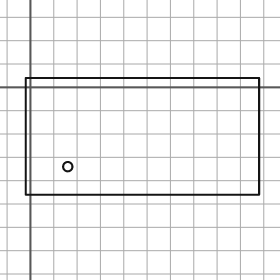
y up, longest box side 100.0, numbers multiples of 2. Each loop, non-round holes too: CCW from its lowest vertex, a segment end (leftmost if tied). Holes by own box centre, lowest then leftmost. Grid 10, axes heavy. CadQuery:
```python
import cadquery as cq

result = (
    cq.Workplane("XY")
    .moveTo(-2.0, -46.0)
    .lineTo(98.0, -46.0)
    .lineTo(98.0, 4.0)
    .lineTo(-2.0, 4.0)
    .close()
    .moveTo(16.0, -34.0)
    .circle(2.0)
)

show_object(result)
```